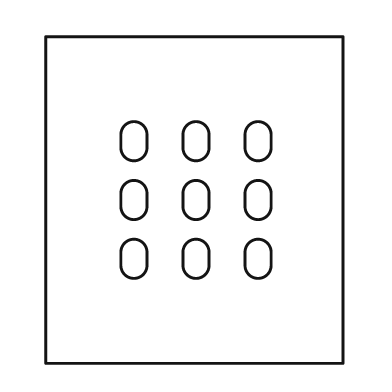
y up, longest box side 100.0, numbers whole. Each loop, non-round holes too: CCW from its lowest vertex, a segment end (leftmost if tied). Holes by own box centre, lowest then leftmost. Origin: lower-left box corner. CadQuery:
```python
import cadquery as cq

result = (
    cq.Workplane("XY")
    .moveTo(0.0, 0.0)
    .lineTo(91.0, 0.0)
    .lineTo(91.0, 100.0)
    .lineTo(0.0, 100.0)
    .close()
    .moveTo(23.0, 30.0)
    .threePointArc((27.0, 26.0), (31.0, 30.0))
    .lineTo(31.0, 34.0)
    .threePointArc((27.0, 38.0), (23.0, 34.0))
    .close()
    .moveTo(42.0, 30.0)
    .threePointArc((46.0, 26.0), (50.0, 30.0))
    .lineTo(50.0, 34.0)
    .threePointArc((46.0, 38.0), (42.0, 34.0))
    .close()
    .moveTo(61.0, 30.0)
    .threePointArc((65.0, 26.0), (69.0, 30.0))
    .lineTo(69.0, 34.0)
    .threePointArc((65.0, 38.0), (61.0, 34.0))
    .close()
    .moveTo(23.0, 48.0)
    .threePointArc((27.0, 44.0), (31.0, 48.0))
    .lineTo(31.0, 52.0)
    .threePointArc((27.0, 56.0), (23.0, 52.0))
    .close()
    .moveTo(42.0, 48.0)
    .threePointArc((46.0, 44.0), (50.0, 48.0))
    .lineTo(50.0, 52.0)
    .threePointArc((46.0, 56.0), (42.0, 52.0))
    .close()
    .moveTo(61.0, 48.0)
    .threePointArc((65.0, 44.0), (69.0, 48.0))
    .lineTo(69.0, 52.0)
    .threePointArc((65.0, 56.0), (61.0, 52.0))
    .close()
    .moveTo(23.0, 66.0)
    .threePointArc((27.0, 62.0), (31.0, 66.0))
    .lineTo(31.0, 70.0)
    .threePointArc((27.0, 74.0), (23.0, 70.0))
    .close()
    .moveTo(42.0, 66.0)
    .threePointArc((46.0, 62.0), (50.0, 66.0))
    .lineTo(50.0, 70.0)
    .threePointArc((46.0, 74.0), (42.0, 70.0))
    .close()
    .moveTo(61.0, 66.0)
    .threePointArc((65.0, 62.0), (69.0, 66.0))
    .lineTo(69.0, 70.0)
    .threePointArc((65.0, 74.0), (61.0, 70.0))
    .close()
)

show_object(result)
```